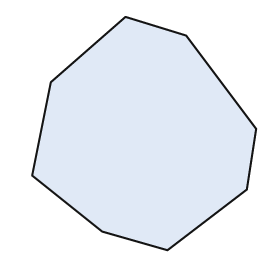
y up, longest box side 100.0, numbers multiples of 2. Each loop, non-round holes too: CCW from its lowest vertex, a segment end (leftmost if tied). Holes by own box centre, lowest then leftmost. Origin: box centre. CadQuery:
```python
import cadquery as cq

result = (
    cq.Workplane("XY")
    .moveTo(10.0, -50.0)
    .lineTo(44.0, -24.0)
    .lineTo(48.0, 2.0)
    .lineTo(18.0, 42.0)
    .lineTo(-8.0, 50.0)
    .lineTo(-40.0, 22.0)
    .lineTo(-48.0, -18.0)
    .lineTo(-18.0, -42.0)
    .close()
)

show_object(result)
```